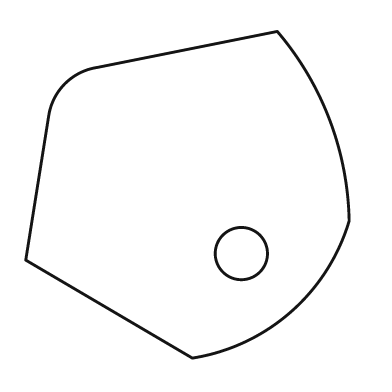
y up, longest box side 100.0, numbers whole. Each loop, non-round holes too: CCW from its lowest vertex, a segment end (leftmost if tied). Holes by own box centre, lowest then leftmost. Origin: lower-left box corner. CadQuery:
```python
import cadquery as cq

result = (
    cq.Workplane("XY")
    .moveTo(51.0, 0.0)
    .threePointArc((81.0, 14.0), (99.0, 42.0))
    .threePointArc((93.0, 73.0), (77.0, 100.0))
    .lineTo(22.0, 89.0)
    .threePointArc((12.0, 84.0), (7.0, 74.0))
    .lineTo(0.0, 30.0)
    .close()
    .moveTo(66.0, 32.0)
    .circle(8.0)
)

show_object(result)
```